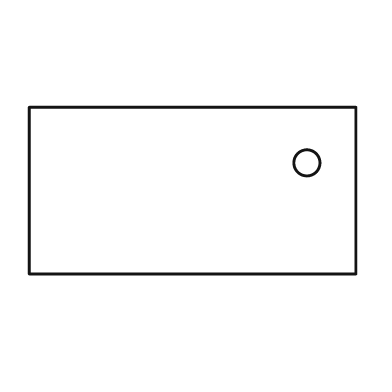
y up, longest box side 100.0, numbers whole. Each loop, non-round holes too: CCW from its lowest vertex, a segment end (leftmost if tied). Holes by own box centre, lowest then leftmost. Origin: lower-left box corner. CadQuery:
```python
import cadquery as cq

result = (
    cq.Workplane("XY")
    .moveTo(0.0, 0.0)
    .lineTo(100.0, 0.0)
    .lineTo(100.0, 51.0)
    .lineTo(0.0, 51.0)
    .close()
    .moveTo(85.0, 34.0)
    .circle(4.0)
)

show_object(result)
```